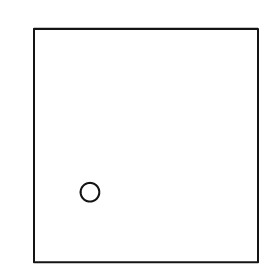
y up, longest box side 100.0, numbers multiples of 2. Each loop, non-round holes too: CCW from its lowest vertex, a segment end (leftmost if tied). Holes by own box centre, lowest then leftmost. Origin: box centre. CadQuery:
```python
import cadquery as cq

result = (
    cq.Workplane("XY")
    .moveTo(-48.0, -50.0)
    .lineTo(48.0, -50.0)
    .lineTo(48.0, 50.0)
    .lineTo(-48.0, 50.0)
    .close()
    .moveTo(-24.0, -20.0)
    .circle(4.0)
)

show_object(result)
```